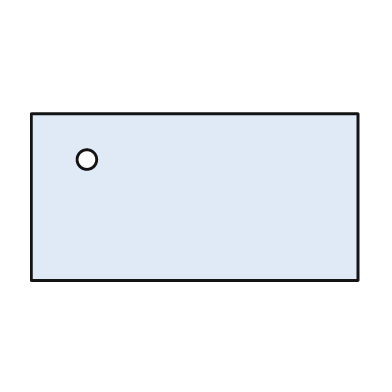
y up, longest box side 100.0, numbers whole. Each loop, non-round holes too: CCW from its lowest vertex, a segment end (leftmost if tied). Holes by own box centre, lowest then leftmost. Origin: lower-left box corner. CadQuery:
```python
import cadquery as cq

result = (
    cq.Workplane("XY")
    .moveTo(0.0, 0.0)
    .lineTo(100.0, 0.0)
    .lineTo(100.0, 51.0)
    .lineTo(0.0, 51.0)
    .close()
    .moveTo(17.0, 37.0)
    .circle(3.0)
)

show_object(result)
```